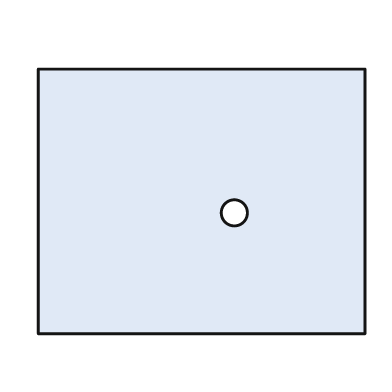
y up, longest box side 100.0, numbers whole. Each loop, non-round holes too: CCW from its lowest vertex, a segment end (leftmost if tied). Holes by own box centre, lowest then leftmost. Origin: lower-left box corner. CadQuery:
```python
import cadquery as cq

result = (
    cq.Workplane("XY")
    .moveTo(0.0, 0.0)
    .lineTo(100.0, 0.0)
    .lineTo(100.0, 81.0)
    .lineTo(0.0, 81.0)
    .close()
    .moveTo(60.0, 37.0)
    .circle(4.0)
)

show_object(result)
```